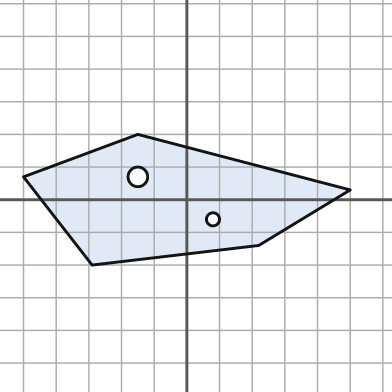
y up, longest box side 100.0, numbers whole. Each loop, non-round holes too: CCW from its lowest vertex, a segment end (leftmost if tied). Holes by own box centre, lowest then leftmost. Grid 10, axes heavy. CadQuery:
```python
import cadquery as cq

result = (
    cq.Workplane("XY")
    .moveTo(-29.0, -20.0)
    .lineTo(22.0, -14.0)
    .lineTo(50.0, 3.0)
    .lineTo(-15.0, 20.0)
    .lineTo(-50.0, 7.0)
    .close()
    .moveTo(8.0, -6.0)
    .circle(2.0)
    .moveTo(-15.0, 7.0)
    .circle(3.0)
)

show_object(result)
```